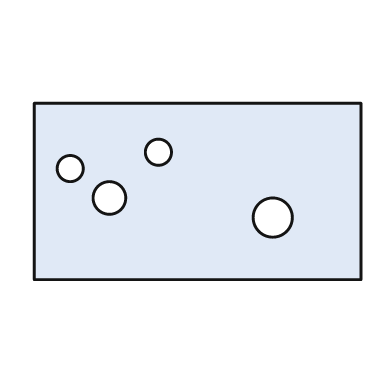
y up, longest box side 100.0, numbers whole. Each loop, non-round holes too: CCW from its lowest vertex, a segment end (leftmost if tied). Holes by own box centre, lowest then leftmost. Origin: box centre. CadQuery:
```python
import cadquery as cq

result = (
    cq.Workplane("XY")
    .moveTo(-50.0, -27.0)
    .lineTo(50.0, -27.0)
    .lineTo(50.0, 27.0)
    .lineTo(-50.0, 27.0)
    .close()
    .moveTo(23.0, -8.0)
    .circle(6.0)
    .moveTo(-27.0, -2.0)
    .circle(5.0)
    .moveTo(-39.0, 7.0)
    .circle(4.0)
    .moveTo(-12.0, 12.0)
    .circle(4.0)
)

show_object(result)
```